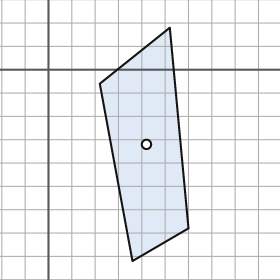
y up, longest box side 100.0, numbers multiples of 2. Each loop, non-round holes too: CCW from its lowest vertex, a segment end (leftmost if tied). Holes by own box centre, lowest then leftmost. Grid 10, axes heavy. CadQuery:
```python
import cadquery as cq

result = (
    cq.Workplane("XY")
    .moveTo(36.0, -82.0)
    .lineTo(60.0, -68.0)
    .lineTo(52.0, 18.0)
    .lineTo(22.0, -6.0)
    .close()
    .moveTo(42.0, -32.0)
    .circle(2.0)
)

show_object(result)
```